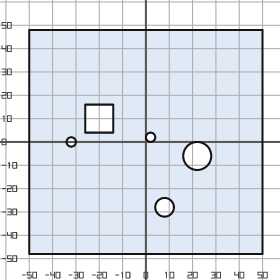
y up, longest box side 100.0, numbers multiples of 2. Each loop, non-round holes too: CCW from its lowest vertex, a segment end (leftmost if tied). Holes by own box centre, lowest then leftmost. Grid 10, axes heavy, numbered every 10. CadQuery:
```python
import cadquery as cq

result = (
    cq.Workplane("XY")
    .moveTo(-50.0, -48.0)
    .lineTo(50.0, -48.0)
    .lineTo(50.0, 48.0)
    .lineTo(-50.0, 48.0)
    .close()
    .moveTo(8.0, -28.0)
    .circle(4.0)
    .moveTo(22.0, -6.0)
    .circle(6.0)
    .moveTo(-32.0, 0.0)
    .circle(2.0)
    .moveTo(2.0, 2.0)
    .circle(2.0)
    .moveTo(-26.0, 4.0)
    .lineTo(-14.0, 4.0)
    .lineTo(-14.0, 16.0)
    .lineTo(-26.0, 16.0)
    .close()
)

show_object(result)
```